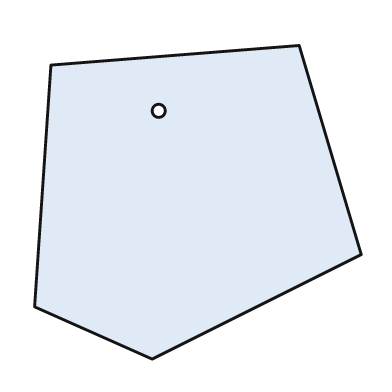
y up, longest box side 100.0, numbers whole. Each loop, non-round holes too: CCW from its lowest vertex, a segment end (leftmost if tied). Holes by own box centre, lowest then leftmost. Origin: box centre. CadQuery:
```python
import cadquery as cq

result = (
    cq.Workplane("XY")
    .moveTo(-14.0, -48.0)
    .lineTo(50.0, -16.0)
    .lineTo(31.0, 48.0)
    .lineTo(-45.0, 42.0)
    .lineTo(-50.0, -32.0)
    .close()
    .moveTo(-12.0, 28.0)
    .circle(2.0)
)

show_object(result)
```